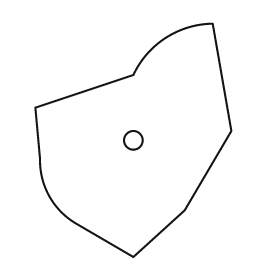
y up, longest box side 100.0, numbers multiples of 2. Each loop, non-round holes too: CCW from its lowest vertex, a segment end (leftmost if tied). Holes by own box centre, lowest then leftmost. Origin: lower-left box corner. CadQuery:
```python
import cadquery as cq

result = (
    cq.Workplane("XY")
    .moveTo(42.0, 0.0)
    .lineTo(64.0, 20.0)
    .lineTo(84.0, 54.0)
    .lineTo(76.0, 100.0)
    .threePointArc((56.0, 94.0), (42.0, 78.0))
    .lineTo(0.0, 64.0)
    .lineTo(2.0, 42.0)
    .threePointArc((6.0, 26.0), (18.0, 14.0))
    .close()
    .moveTo(42.0, 50.0)
    .circle(4.0)
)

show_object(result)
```